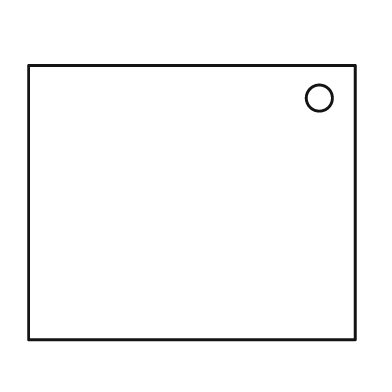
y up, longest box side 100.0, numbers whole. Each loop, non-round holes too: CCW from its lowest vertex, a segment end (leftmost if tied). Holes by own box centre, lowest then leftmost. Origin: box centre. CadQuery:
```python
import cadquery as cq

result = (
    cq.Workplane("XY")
    .moveTo(-50.0, -42.0)
    .lineTo(50.0, -42.0)
    .lineTo(50.0, 42.0)
    .lineTo(-50.0, 42.0)
    .close()
    .moveTo(39.0, 32.0)
    .circle(4.0)
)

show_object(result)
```